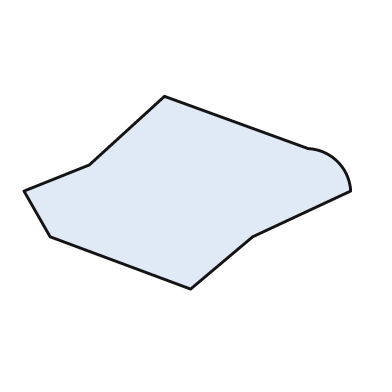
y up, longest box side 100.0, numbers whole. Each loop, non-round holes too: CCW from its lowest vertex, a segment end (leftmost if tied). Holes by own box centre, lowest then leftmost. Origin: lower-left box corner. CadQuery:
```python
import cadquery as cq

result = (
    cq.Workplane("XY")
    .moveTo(51.0, 0.0)
    .lineTo(70.0, 16.0)
    .lineTo(100.0, 30.0)
    .threePointArc((96.0, 39.0), (87.0, 43.0))
    .lineTo(43.0, 59.0)
    .lineTo(20.0, 38.0)
    .lineTo(0.0, 30.0)
    .lineTo(8.0, 16.0)
    .close()
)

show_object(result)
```